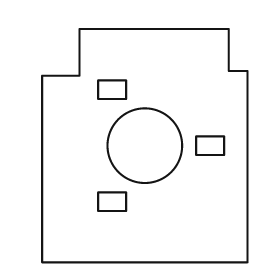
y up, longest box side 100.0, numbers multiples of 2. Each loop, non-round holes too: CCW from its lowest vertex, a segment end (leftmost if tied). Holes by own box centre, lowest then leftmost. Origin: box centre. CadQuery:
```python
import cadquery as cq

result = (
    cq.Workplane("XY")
    .moveTo(-44.0, -50.0)
    .lineTo(44.0, -50.0)
    .lineTo(44.0, 32.0)
    .lineTo(36.0, 32.0)
    .lineTo(36.0, 50.0)
    .lineTo(-28.0, 50.0)
    .lineTo(-28.0, 30.0)
    .lineTo(-44.0, 30.0)
    .close()
    .moveTo(-20.0, -28.0)
    .lineTo(-8.0, -28.0)
    .lineTo(-8.0, -20.0)
    .lineTo(-20.0, -20.0)
    .close()
    .moveTo(0.0, 0.0)
    .circle(16.0)
    .moveTo(22.0, -4.0)
    .lineTo(34.0, -4.0)
    .lineTo(34.0, 4.0)
    .lineTo(22.0, 4.0)
    .close()
    .moveTo(-20.0, 20.0)
    .lineTo(-8.0, 20.0)
    .lineTo(-8.0, 28.0)
    .lineTo(-20.0, 28.0)
    .close()
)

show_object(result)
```